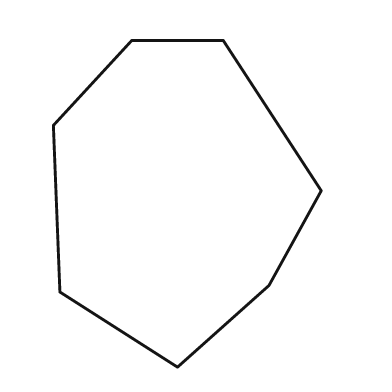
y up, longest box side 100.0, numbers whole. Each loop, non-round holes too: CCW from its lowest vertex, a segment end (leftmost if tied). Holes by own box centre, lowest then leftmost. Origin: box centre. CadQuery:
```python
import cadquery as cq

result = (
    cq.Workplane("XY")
    .moveTo(-3.0, -50.0)
    .lineTo(25.0, -25.0)
    .lineTo(41.0, 4.0)
    .lineTo(11.0, 50.0)
    .lineTo(-17.0, 50.0)
    .lineTo(-41.0, 24.0)
    .lineTo(-39.0, -27.0)
    .close()
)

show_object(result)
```